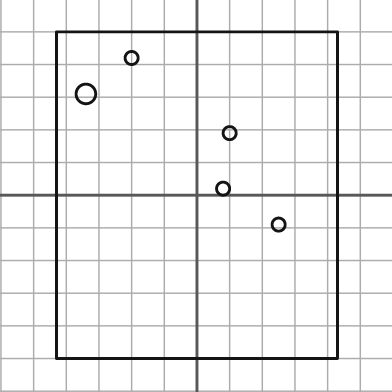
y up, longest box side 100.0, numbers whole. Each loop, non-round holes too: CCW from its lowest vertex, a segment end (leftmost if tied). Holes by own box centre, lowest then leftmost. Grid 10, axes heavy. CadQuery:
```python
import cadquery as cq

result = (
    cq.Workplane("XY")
    .moveTo(-43.0, -50.0)
    .lineTo(43.0, -50.0)
    .lineTo(43.0, 50.0)
    .lineTo(-43.0, 50.0)
    .close()
    .moveTo(25.0, -9.0)
    .circle(2.0)
    .moveTo(8.0, 2.0)
    .circle(2.0)
    .moveTo(10.0, 19.0)
    .circle(2.0)
    .moveTo(-34.0, 31.0)
    .circle(3.0)
    .moveTo(-20.0, 42.0)
    .circle(2.0)
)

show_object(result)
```